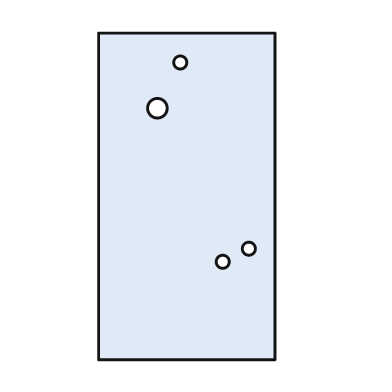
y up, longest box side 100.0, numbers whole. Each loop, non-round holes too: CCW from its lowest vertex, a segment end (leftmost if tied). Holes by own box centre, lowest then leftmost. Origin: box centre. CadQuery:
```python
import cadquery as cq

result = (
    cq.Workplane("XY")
    .moveTo(-27.0, -50.0)
    .lineTo(27.0, -50.0)
    .lineTo(27.0, 50.0)
    .lineTo(-27.0, 50.0)
    .close()
    .moveTo(11.0, -20.0)
    .circle(2.0)
    .moveTo(19.0, -16.0)
    .circle(2.0)
    .moveTo(-9.0, 27.0)
    .circle(3.0)
    .moveTo(-2.0, 41.0)
    .circle(2.0)
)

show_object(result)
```